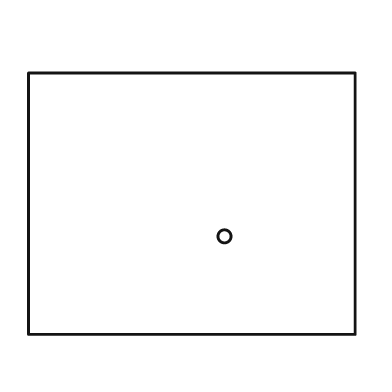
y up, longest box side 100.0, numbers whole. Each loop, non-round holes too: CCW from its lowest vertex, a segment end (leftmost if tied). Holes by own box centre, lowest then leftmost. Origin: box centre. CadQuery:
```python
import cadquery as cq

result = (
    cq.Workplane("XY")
    .moveTo(-50.0, -40.0)
    .lineTo(50.0, -40.0)
    .lineTo(50.0, 40.0)
    .lineTo(-50.0, 40.0)
    .close()
    .moveTo(10.0, -10.0)
    .circle(2.0)
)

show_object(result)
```